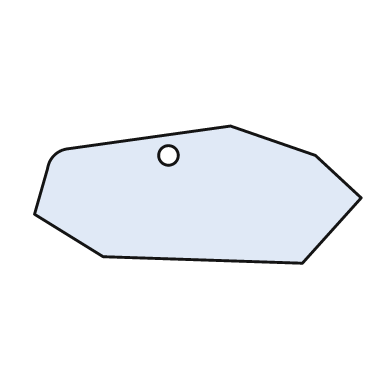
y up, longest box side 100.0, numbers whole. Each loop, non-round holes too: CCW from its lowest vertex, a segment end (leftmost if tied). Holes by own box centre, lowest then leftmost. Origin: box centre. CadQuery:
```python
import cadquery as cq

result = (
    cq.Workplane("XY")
    .moveTo(32.0, -21.0)
    .lineTo(50.0, -1.0)
    .lineTo(36.0, 12.0)
    .lineTo(10.0, 21.0)
    .lineTo(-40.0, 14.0)
    .threePointArc((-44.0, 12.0), (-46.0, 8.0))
    .lineTo(-50.0, -6.0)
    .lineTo(-29.0, -19.0)
    .close()
    .moveTo(-9.0, 12.0)
    .circle(3.0)
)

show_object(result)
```